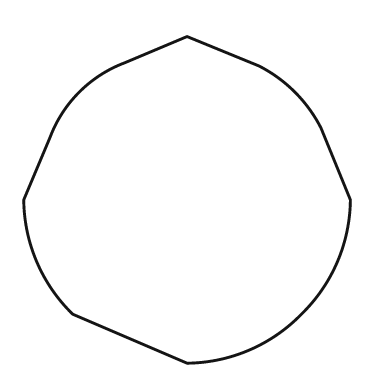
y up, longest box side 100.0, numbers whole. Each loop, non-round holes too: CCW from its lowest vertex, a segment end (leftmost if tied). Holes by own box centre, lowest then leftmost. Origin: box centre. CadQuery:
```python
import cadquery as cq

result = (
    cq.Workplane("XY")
    .moveTo(0.0, -50.0)
    .threePointArc((19.0, -46.0), (35.0, -35.0))
    .threePointArc((46.0, -19.0), (50.0, 0.0))
    .lineTo(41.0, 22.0)
    .threePointArc((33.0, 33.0), (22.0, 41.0))
    .lineTo(0.0, 50.0)
    .lineTo(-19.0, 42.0)
    .threePointArc((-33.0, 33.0), (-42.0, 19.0))
    .lineTo(-50.0, 0.0)
    .threePointArc((-46.0, -19.0), (-35.0, -35.0))
    .close()
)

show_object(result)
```